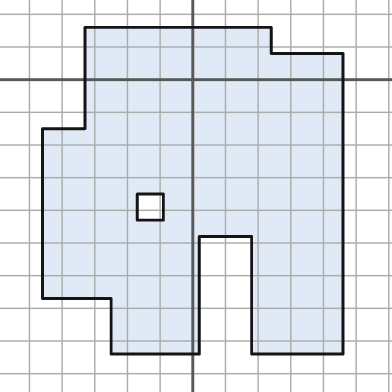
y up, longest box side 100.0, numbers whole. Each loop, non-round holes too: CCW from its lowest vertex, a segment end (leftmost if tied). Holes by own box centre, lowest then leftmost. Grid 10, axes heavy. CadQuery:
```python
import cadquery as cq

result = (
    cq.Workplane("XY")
    .moveTo(-25.0, -84.0)
    .lineTo(2.0, -84.0)
    .lineTo(2.0, -48.0)
    .lineTo(18.0, -48.0)
    .lineTo(18.0, -84.0)
    .lineTo(46.0, -84.0)
    .lineTo(46.0, 8.0)
    .lineTo(24.0, 8.0)
    .lineTo(24.0, 16.0)
    .lineTo(-33.0, 16.0)
    .lineTo(-33.0, -15.0)
    .lineTo(-46.0, -15.0)
    .lineTo(-46.0, -67.0)
    .lineTo(-25.0, -67.0)
    .close()
    .moveTo(-17.0, -43.0)
    .lineTo(-9.0, -43.0)
    .lineTo(-9.0, -35.0)
    .lineTo(-17.0, -35.0)
    .close()
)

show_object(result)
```